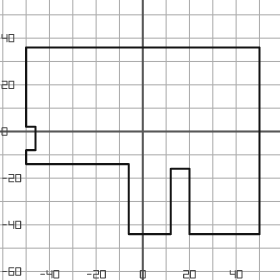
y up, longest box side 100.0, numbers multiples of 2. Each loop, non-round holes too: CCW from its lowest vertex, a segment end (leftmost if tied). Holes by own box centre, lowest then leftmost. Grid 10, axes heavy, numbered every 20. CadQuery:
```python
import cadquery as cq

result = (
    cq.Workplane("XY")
    .moveTo(-6.0, -44.0)
    .lineTo(12.0, -44.0)
    .lineTo(12.0, -16.0)
    .lineTo(20.0, -16.0)
    .lineTo(20.0, -44.0)
    .lineTo(50.0, -44.0)
    .lineTo(50.0, 36.0)
    .lineTo(-50.0, 36.0)
    .lineTo(-50.0, 2.0)
    .lineTo(-46.0, 2.0)
    .lineTo(-46.0, -8.0)
    .lineTo(-50.0, -8.0)
    .lineTo(-50.0, -14.0)
    .lineTo(-6.0, -14.0)
    .close()
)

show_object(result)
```